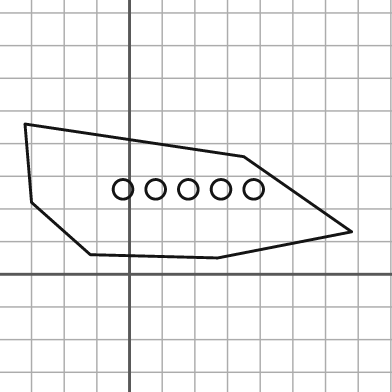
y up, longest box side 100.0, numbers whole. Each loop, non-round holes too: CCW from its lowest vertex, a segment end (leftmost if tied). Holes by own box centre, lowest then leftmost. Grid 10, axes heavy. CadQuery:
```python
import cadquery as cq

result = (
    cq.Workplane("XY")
    .moveTo(27.0, 5.0)
    .lineTo(68.0, 13.0)
    .lineTo(35.0, 36.0)
    .lineTo(-32.0, 46.0)
    .lineTo(-30.0, 22.0)
    .lineTo(-12.0, 6.0)
    .close()
    .moveTo(-2.0, 26.0)
    .circle(3.0)
    .moveTo(8.0, 26.0)
    .circle(3.0)
    .moveTo(18.0, 26.0)
    .circle(3.0)
    .moveTo(28.0, 26.0)
    .circle(3.0)
    .moveTo(38.0, 26.0)
    .circle(3.0)
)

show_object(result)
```